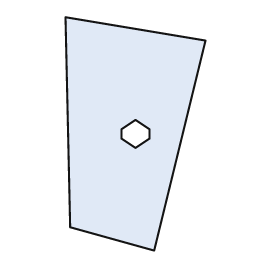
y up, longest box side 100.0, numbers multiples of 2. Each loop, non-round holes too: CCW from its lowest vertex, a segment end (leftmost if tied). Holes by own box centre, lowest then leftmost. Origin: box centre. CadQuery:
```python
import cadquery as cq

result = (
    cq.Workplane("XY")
    .moveTo(8.0, -50.0)
    .lineTo(30.0, 40.0)
    .lineTo(-30.0, 50.0)
    .lineTo(-28.0, -40.0)
    .close()
    .moveTo(0.0, -6.0)
    .lineTo(6.0, -2.0)
    .lineTo(6.0, 2.0)
    .lineTo(0.0, 6.0)
    .lineTo(-6.0, 2.0)
    .lineTo(-6.0, -2.0)
    .close()
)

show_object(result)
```